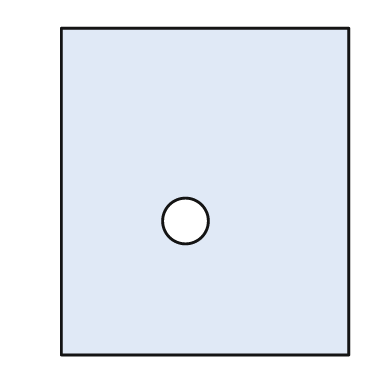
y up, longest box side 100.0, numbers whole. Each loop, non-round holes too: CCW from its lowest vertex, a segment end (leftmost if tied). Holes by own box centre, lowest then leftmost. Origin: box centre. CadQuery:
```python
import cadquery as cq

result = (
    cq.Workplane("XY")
    .moveTo(-44.0, -50.0)
    .lineTo(44.0, -50.0)
    .lineTo(44.0, 50.0)
    .lineTo(-44.0, 50.0)
    .close()
    .moveTo(-6.0, -9.0)
    .circle(7.0)
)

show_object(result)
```